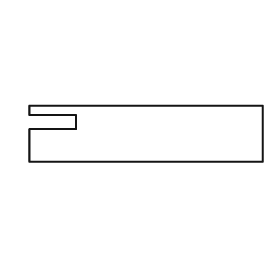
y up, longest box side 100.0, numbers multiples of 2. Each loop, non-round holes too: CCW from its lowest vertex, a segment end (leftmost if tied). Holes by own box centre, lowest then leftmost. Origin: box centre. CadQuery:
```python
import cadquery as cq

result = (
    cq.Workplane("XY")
    .moveTo(-50.0, -12.0)
    .lineTo(50.0, -12.0)
    .lineTo(50.0, 12.0)
    .lineTo(-50.0, 12.0)
    .lineTo(-50.0, 8.0)
    .lineTo(-30.0, 8.0)
    .lineTo(-30.0, 2.0)
    .lineTo(-50.0, 2.0)
    .close()
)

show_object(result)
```